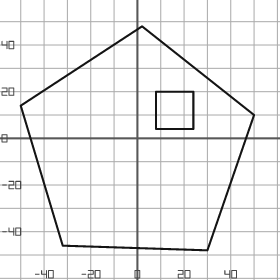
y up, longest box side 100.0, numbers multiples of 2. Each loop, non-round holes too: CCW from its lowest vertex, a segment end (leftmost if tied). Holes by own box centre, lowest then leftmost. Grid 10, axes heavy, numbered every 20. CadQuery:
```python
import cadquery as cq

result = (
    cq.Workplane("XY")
    .moveTo(30.0, -48.0)
    .lineTo(50.0, 10.0)
    .lineTo(2.0, 48.0)
    .lineTo(-50.0, 14.0)
    .lineTo(-32.0, -46.0)
    .close()
    .moveTo(8.0, 4.0)
    .lineTo(24.0, 4.0)
    .lineTo(24.0, 20.0)
    .lineTo(8.0, 20.0)
    .close()
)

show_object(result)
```